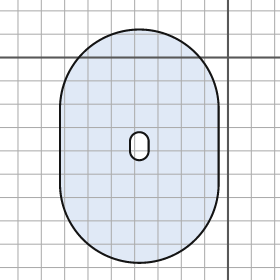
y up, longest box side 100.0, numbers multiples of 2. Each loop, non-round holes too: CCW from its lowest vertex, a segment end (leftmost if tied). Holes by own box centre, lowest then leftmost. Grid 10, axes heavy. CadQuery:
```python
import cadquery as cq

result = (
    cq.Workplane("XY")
    .moveTo(-72.0, -54.0)
    .threePointArc((-38.0, -88.0), (-4.0, -54.0))
    .lineTo(-4.0, -22.0)
    .threePointArc((-38.0, 12.0), (-72.0, -22.0))
    .close()
    .moveTo(-42.0, -40.0)
    .threePointArc((-38.0, -44.0), (-34.0, -40.0))
    .lineTo(-34.0, -36.0)
    .threePointArc((-38.0, -32.0), (-42.0, -36.0))
    .close()
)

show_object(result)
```